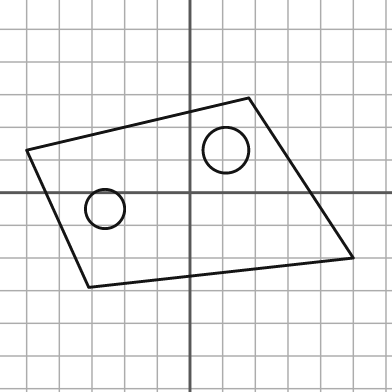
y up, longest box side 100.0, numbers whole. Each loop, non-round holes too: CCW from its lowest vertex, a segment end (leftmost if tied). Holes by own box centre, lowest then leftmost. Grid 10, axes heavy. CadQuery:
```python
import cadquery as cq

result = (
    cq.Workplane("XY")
    .moveTo(-31.0, -29.0)
    .lineTo(50.0, -20.0)
    .lineTo(18.0, 29.0)
    .lineTo(-50.0, 13.0)
    .close()
    .moveTo(-26.0, -5.0)
    .circle(6.0)
    .moveTo(11.0, 13.0)
    .circle(7.0)
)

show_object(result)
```